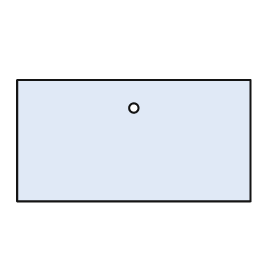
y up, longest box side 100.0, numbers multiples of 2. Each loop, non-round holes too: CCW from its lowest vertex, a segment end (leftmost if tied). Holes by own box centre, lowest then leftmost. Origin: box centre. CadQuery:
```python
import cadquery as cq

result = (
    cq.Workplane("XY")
    .moveTo(-50.0, -26.0)
    .lineTo(50.0, -26.0)
    .lineTo(50.0, 26.0)
    .lineTo(-50.0, 26.0)
    .close()
    .moveTo(0.0, 14.0)
    .circle(2.0)
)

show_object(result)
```